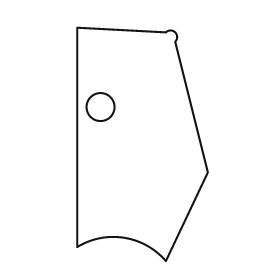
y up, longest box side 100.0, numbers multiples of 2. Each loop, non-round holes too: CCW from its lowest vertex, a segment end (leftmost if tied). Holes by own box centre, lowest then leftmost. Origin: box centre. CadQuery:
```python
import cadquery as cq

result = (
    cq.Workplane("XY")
    .moveTo(10.0, -50.0)
    .lineTo(28.0, -12.0)
    .lineTo(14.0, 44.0)
    .threePointArc((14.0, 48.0), (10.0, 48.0))
    .lineTo(-28.0, 50.0)
    .lineTo(-28.0, -44.0)
    .threePointArc((-8.0, -40.0), (10.0, -50.0))
    .close()
    .moveTo(-18.0, 16.0)
    .circle(6.0)
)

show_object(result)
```